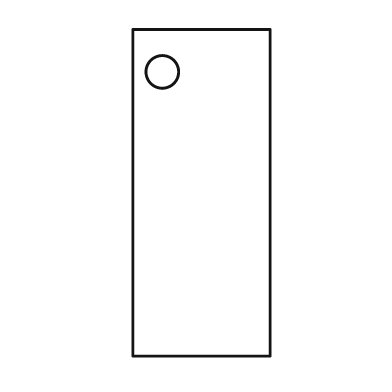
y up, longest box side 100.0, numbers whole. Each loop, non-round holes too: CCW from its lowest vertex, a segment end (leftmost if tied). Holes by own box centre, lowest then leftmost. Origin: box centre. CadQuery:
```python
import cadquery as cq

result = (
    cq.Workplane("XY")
    .moveTo(-21.0, -50.0)
    .lineTo(21.0, -50.0)
    .lineTo(21.0, 50.0)
    .lineTo(-21.0, 50.0)
    .close()
    .moveTo(-12.0, 37.0)
    .circle(5.0)
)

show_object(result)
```